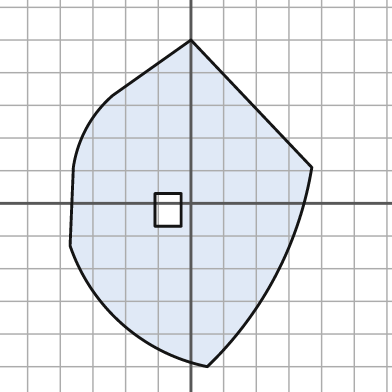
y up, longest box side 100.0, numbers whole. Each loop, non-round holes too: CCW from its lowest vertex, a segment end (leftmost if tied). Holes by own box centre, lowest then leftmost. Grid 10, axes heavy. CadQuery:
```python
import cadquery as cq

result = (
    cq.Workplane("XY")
    .moveTo(5.0, -50.0)
    .threePointArc((26.0, -22.0), (37.0, 11.0))
    .lineTo(0.0, 50.0)
    .lineTo(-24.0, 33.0)
    .threePointArc((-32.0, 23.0), (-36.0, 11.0))
    .lineTo(-37.0, -13.0)
    .threePointArc((-21.0, -37.0), (5.0, -50.0))
    .close()
    .moveTo(-11.0, -7.0)
    .lineTo(-3.0, -7.0)
    .lineTo(-3.0, 3.0)
    .lineTo(-11.0, 3.0)
    .close()
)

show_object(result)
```